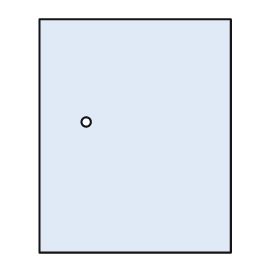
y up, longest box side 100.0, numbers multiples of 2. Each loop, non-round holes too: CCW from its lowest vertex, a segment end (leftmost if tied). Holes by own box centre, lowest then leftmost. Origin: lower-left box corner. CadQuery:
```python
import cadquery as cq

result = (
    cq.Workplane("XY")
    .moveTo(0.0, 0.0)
    .lineTo(82.0, 0.0)
    .lineTo(82.0, 100.0)
    .lineTo(0.0, 100.0)
    .close()
    .moveTo(20.0, 56.0)
    .circle(2.0)
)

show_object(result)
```